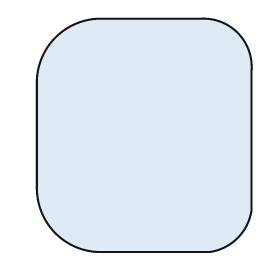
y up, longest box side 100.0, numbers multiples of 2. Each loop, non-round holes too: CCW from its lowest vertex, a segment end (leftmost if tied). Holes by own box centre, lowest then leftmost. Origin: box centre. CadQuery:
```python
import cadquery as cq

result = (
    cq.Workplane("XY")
    .moveTo(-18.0, -50.0)
    .lineTo(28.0, -50.0)
    .threePointArc((40.0, -44.0), (46.0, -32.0))
    .lineTo(46.0, 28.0)
    .threePointArc((40.0, 44.0), (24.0, 50.0))
    .lineTo(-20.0, 50.0)
    .threePointArc((-38.0, 42.0), (-46.0, 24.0))
    .lineTo(-46.0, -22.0)
    .threePointArc((-38.0, -42.0), (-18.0, -50.0))
    .close()
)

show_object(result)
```